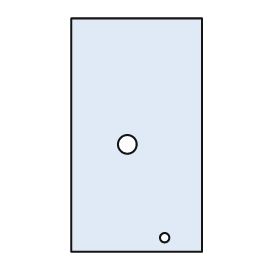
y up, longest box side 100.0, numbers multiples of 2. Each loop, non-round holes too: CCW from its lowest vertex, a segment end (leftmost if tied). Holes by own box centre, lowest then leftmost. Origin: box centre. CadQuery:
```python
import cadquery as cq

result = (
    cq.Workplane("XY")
    .moveTo(-28.0, -50.0)
    .lineTo(28.0, -50.0)
    .lineTo(28.0, 50.0)
    .lineTo(-28.0, 50.0)
    .close()
    .moveTo(12.0, -44.0)
    .circle(2.0)
    .moveTo(-4.0, -4.0)
    .circle(4.0)
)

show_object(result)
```